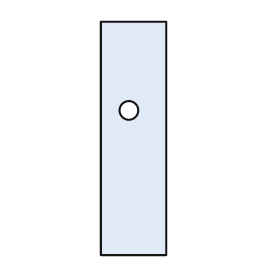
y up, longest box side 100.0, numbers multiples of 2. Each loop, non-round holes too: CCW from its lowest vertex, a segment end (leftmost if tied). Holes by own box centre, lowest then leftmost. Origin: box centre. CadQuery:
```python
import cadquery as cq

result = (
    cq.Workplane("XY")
    .moveTo(-14.0, -50.0)
    .lineTo(14.0, -50.0)
    .lineTo(14.0, 50.0)
    .lineTo(-14.0, 50.0)
    .close()
    .moveTo(-2.0, 12.0)
    .circle(4.0)
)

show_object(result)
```